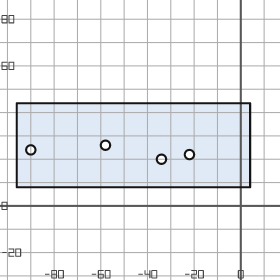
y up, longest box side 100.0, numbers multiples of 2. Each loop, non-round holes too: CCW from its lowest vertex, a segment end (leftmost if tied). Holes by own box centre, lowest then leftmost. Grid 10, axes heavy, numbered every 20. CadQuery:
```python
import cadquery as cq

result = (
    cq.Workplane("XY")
    .moveTo(-96.0, 8.0)
    .lineTo(4.0, 8.0)
    .lineTo(4.0, 44.0)
    .lineTo(-96.0, 44.0)
    .close()
    .moveTo(-34.0, 20.0)
    .circle(2.0)
    .moveTo(-22.0, 22.0)
    .circle(2.0)
    .moveTo(-90.0, 24.0)
    .circle(2.0)
    .moveTo(-58.0, 26.0)
    .circle(2.0)
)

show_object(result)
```